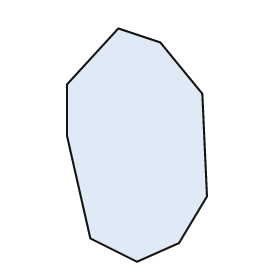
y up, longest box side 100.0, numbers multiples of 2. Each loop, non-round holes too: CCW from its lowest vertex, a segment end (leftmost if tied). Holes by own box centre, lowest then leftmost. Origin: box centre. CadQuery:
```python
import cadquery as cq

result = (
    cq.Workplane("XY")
    .moveTo(0.0, -50.0)
    .lineTo(18.0, -42.0)
    .lineTo(30.0, -22.0)
    .lineTo(28.0, 22.0)
    .lineTo(10.0, 44.0)
    .lineTo(-8.0, 50.0)
    .lineTo(-30.0, 26.0)
    .lineTo(-30.0, 4.0)
    .lineTo(-20.0, -40.0)
    .close()
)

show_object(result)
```